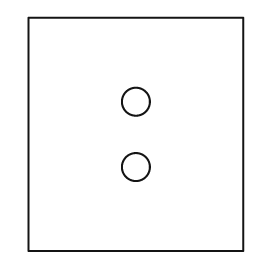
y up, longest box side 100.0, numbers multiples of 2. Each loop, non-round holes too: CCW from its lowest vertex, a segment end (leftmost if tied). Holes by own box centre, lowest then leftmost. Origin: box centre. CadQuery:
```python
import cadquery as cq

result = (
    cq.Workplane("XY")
    .moveTo(-46.0, -50.0)
    .lineTo(46.0, -50.0)
    .lineTo(46.0, 50.0)
    .lineTo(-46.0, 50.0)
    .close()
    .moveTo(0.0, -14.0)
    .circle(6.0)
    .moveTo(0.0, 14.0)
    .circle(6.0)
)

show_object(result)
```